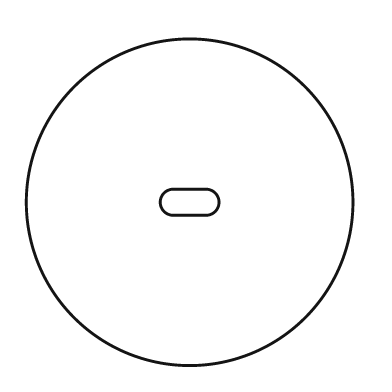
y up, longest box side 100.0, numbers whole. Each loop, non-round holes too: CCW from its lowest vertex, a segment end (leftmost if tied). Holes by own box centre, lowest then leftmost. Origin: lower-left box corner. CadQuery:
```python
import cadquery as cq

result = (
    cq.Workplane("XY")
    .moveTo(50.0, 50.0)
    .circle(50.0)
    .moveTo(45.0, 46.0)
    .lineTo(55.0, 46.0)
    .threePointArc((59.0, 50.0), (55.0, 54.0))
    .lineTo(45.0, 54.0)
    .threePointArc((41.0, 50.0), (45.0, 46.0))
    .close()
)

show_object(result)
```